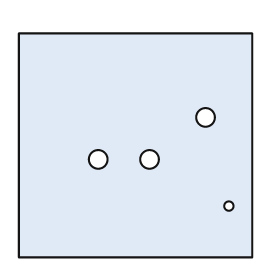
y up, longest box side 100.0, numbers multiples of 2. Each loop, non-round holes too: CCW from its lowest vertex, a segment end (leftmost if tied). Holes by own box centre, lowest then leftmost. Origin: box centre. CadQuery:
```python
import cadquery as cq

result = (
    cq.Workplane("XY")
    .moveTo(-50.0, -48.0)
    .lineTo(50.0, -48.0)
    .lineTo(50.0, 48.0)
    .lineTo(-50.0, 48.0)
    .close()
    .moveTo(40.0, -26.0)
    .circle(2.0)
    .moveTo(-16.0, -6.0)
    .circle(4.0)
    .moveTo(6.0, -6.0)
    .circle(4.0)
    .moveTo(30.0, 12.0)
    .circle(4.0)
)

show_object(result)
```